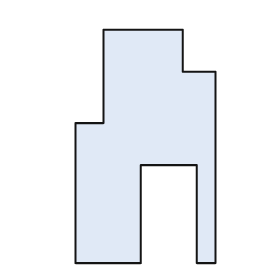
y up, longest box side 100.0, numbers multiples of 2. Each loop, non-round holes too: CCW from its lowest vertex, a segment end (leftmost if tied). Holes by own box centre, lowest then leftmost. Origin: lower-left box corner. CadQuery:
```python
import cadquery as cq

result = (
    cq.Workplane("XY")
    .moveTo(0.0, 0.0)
    .lineTo(28.0, 0.0)
    .lineTo(28.0, 42.0)
    .lineTo(52.0, 42.0)
    .lineTo(52.0, 0.0)
    .lineTo(60.0, 0.0)
    .lineTo(60.0, 82.0)
    .lineTo(46.0, 82.0)
    .lineTo(46.0, 100.0)
    .lineTo(12.0, 100.0)
    .lineTo(12.0, 60.0)
    .lineTo(0.0, 60.0)
    .close()
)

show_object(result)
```